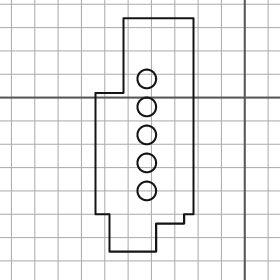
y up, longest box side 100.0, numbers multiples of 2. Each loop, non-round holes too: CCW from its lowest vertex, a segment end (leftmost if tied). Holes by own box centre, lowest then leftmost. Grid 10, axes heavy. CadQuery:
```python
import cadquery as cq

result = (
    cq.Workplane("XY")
    .moveTo(-58.0, -66.0)
    .lineTo(-38.0, -66.0)
    .lineTo(-38.0, -54.0)
    .lineTo(-26.0, -54.0)
    .lineTo(-26.0, -50.0)
    .lineTo(-22.0, -50.0)
    .lineTo(-22.0, 34.0)
    .lineTo(-52.0, 34.0)
    .lineTo(-52.0, 2.0)
    .lineTo(-64.0, 2.0)
    .lineTo(-64.0, -50.0)
    .lineTo(-58.0, -50.0)
    .close()
    .moveTo(-42.0, -40.0)
    .circle(4.0)
    .moveTo(-42.0, -28.0)
    .circle(4.0)
    .moveTo(-42.0, -16.0)
    .circle(4.0)
    .moveTo(-42.0, -4.0)
    .circle(4.0)
    .moveTo(-42.0, 8.0)
    .circle(4.0)
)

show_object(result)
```